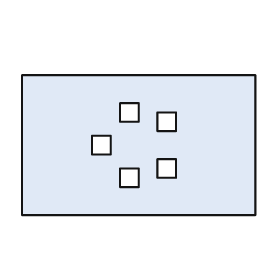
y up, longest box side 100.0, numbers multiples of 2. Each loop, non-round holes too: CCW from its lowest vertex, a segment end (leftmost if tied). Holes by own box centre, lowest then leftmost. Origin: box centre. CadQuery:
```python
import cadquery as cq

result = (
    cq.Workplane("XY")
    .moveTo(-50.0, -30.0)
    .lineTo(50.0, -30.0)
    .lineTo(50.0, 30.0)
    .lineTo(-50.0, 30.0)
    .close()
    .moveTo(-8.0, -18.0)
    .lineTo(0.0, -18.0)
    .lineTo(0.0, -10.0)
    .lineTo(-8.0, -10.0)
    .close()
    .moveTo(8.0, -14.0)
    .lineTo(16.0, -14.0)
    .lineTo(16.0, -6.0)
    .lineTo(8.0, -6.0)
    .close()
    .moveTo(-20.0, -4.0)
    .lineTo(-12.0, -4.0)
    .lineTo(-12.0, 4.0)
    .lineTo(-20.0, 4.0)
    .close()
    .moveTo(8.0, 6.0)
    .lineTo(16.0, 6.0)
    .lineTo(16.0, 14.0)
    .lineTo(8.0, 14.0)
    .close()
    .moveTo(-8.0, 10.0)
    .lineTo(0.0, 10.0)
    .lineTo(0.0, 18.0)
    .lineTo(-8.0, 18.0)
    .close()
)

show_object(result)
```